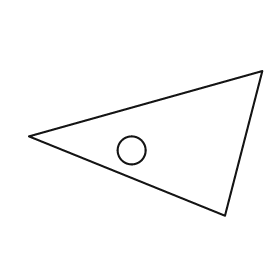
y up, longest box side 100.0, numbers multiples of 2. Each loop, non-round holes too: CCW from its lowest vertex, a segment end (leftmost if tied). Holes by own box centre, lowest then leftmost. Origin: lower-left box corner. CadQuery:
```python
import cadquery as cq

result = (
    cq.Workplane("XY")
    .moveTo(84.0, 0.0)
    .lineTo(100.0, 62.0)
    .lineTo(0.0, 34.0)
    .close()
    .moveTo(44.0, 28.0)
    .circle(6.0)
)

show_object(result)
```